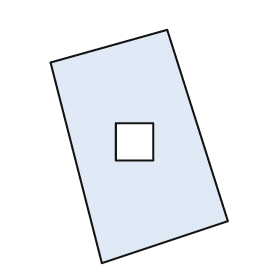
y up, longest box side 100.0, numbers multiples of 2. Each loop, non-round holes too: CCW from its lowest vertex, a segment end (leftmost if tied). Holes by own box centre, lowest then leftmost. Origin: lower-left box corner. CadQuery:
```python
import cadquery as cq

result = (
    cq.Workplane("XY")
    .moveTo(22.0, 0.0)
    .lineTo(76.0, 18.0)
    .lineTo(50.0, 100.0)
    .lineTo(0.0, 86.0)
    .close()
    .moveTo(28.0, 44.0)
    .lineTo(44.0, 44.0)
    .lineTo(44.0, 60.0)
    .lineTo(28.0, 60.0)
    .close()
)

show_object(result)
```